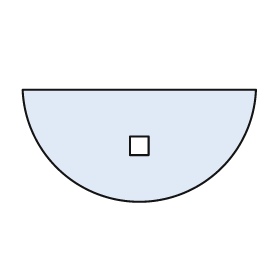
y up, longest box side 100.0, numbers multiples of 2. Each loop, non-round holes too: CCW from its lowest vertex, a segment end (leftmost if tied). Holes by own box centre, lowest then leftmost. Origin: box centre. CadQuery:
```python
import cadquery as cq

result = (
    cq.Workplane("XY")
    .moveTo(-50.0, 24.0)
    .threePointArc((0.0, -24.0), (50.0, 24.0))
    .close()
    .moveTo(-4.0, -4.0)
    .lineTo(4.0, -4.0)
    .lineTo(4.0, 4.0)
    .lineTo(-4.0, 4.0)
    .close()
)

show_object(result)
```